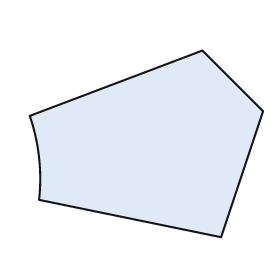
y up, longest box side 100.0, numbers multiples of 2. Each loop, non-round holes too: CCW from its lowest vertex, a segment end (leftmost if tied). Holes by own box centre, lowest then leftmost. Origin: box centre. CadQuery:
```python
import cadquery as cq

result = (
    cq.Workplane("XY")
    .moveTo(32.0, -40.0)
    .lineTo(50.0, 14.0)
    .lineTo(24.0, 40.0)
    .lineTo(-50.0, 12.0)
    .threePointArc((-46.0, -6.0), (-46.0, -24.0))
    .close()
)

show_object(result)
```